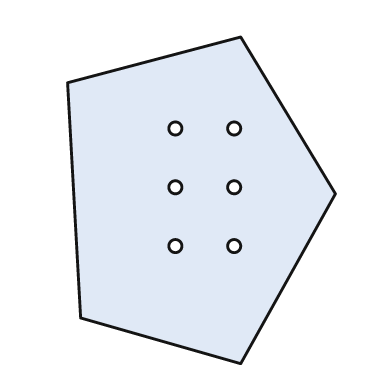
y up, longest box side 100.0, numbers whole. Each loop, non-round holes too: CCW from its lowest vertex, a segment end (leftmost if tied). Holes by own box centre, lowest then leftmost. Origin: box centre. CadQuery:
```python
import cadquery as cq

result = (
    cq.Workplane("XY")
    .moveTo(12.0, -50.0)
    .lineTo(41.0, 2.0)
    .lineTo(12.0, 50.0)
    .lineTo(-41.0, 36.0)
    .lineTo(-37.0, -36.0)
    .close()
    .moveTo(-8.0, -14.0)
    .circle(2.0)
    .moveTo(10.0, -14.0)
    .circle(2.0)
    .moveTo(-8.0, 4.0)
    .circle(2.0)
    .moveTo(10.0, 4.0)
    .circle(2.0)
    .moveTo(-8.0, 22.0)
    .circle(2.0)
    .moveTo(10.0, 22.0)
    .circle(2.0)
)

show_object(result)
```